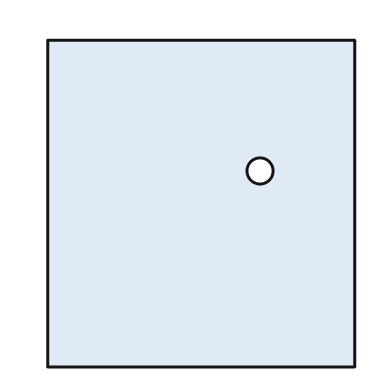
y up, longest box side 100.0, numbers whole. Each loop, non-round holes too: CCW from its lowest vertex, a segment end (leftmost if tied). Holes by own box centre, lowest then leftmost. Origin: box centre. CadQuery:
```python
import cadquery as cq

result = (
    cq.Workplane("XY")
    .moveTo(-47.0, -50.0)
    .lineTo(47.0, -50.0)
    .lineTo(47.0, 50.0)
    .lineTo(-47.0, 50.0)
    .close()
    .moveTo(18.0, 10.0)
    .circle(4.0)
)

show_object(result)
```